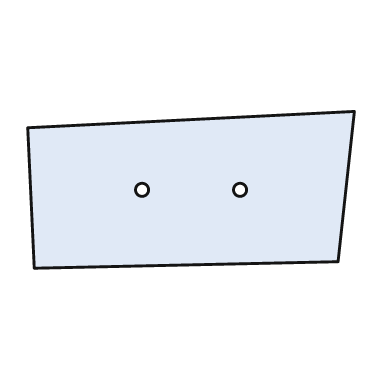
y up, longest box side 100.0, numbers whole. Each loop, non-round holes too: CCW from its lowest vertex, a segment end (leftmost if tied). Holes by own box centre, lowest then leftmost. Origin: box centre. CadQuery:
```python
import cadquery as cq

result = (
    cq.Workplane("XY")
    .moveTo(-48.0, -24.0)
    .lineTo(45.0, -22.0)
    .lineTo(50.0, 24.0)
    .lineTo(-50.0, 19.0)
    .close()
    .moveTo(-15.0, 0.0)
    .circle(2.0)
    .moveTo(15.0, 0.0)
    .circle(2.0)
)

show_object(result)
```